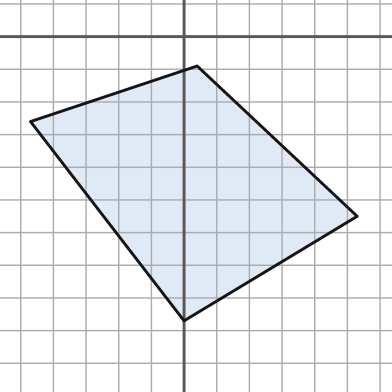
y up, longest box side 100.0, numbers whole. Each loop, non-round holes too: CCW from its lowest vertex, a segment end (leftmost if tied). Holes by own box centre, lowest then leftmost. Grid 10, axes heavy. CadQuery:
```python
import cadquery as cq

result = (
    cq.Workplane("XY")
    .moveTo(0.0, -87.0)
    .lineTo(53.0, -55.0)
    .lineTo(4.0, -9.0)
    .lineTo(-47.0, -26.0)
    .close()
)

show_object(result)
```